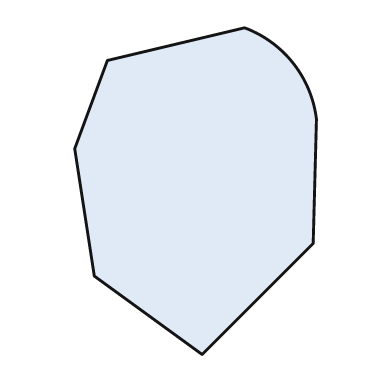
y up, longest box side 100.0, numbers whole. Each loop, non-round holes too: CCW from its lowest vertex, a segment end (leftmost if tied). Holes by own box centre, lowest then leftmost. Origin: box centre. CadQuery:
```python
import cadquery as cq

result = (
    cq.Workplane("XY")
    .moveTo(2.0, -50.0)
    .lineTo(36.0, -16.0)
    .lineTo(37.0, 22.0)
    .threePointArc((30.0, 39.0), (15.0, 50.0))
    .lineTo(-27.0, 40.0)
    .lineTo(-37.0, 13.0)
    .lineTo(-31.0, -26.0)
    .close()
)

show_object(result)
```